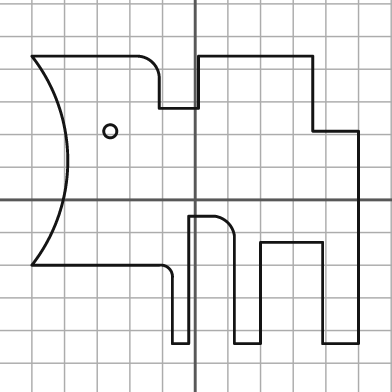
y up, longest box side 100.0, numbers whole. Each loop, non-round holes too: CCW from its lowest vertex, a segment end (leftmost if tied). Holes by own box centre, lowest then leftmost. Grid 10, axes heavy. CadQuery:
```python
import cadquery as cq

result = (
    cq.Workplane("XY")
    .moveTo(-7.0, -44.0)
    .lineTo(-2.0, -44.0)
    .lineTo(-2.0, -5.0)
    .lineTo(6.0, -5.0)
    .threePointArc((10.0, -7.0), (12.0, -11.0))
    .lineTo(12.0, -44.0)
    .lineTo(20.0, -44.0)
    .lineTo(20.0, -13.0)
    .lineTo(39.0, -13.0)
    .lineTo(39.0, -44.0)
    .lineTo(50.0, -44.0)
    .lineTo(50.0, 21.0)
    .lineTo(36.0, 21.0)
    .lineTo(36.0, 44.0)
    .lineTo(1.0, 44.0)
    .lineTo(1.0, 28.0)
    .lineTo(-11.0, 28.0)
    .lineTo(-11.0, 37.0)
    .threePointArc((-13.0, 42.0), (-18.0, 44.0))
    .lineTo(-50.0, 44.0)
    .threePointArc((-39.0, 12.0), (-50.0, -20.0))
    .lineTo(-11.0, -20.0)
    .threePointArc((-8.0, -21.0), (-7.0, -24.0))
    .close()
    .moveTo(-26.0, 21.0)
    .circle(2.0)
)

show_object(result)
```